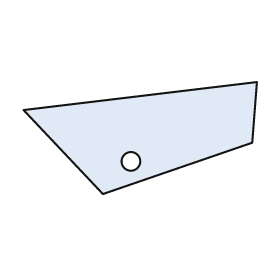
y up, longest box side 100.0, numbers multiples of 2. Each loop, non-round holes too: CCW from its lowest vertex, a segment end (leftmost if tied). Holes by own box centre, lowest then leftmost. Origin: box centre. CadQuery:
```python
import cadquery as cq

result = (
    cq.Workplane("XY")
    .moveTo(-16.0, -24.0)
    .lineTo(48.0, -2.0)
    .lineTo(50.0, 24.0)
    .lineTo(-50.0, 12.0)
    .close()
    .moveTo(-4.0, -10.0)
    .circle(4.0)
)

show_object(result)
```